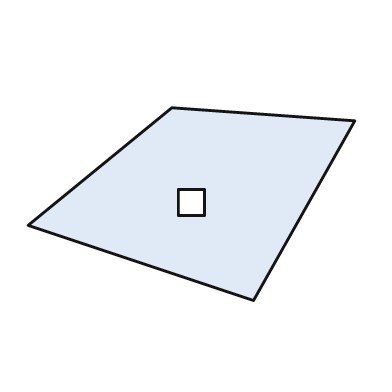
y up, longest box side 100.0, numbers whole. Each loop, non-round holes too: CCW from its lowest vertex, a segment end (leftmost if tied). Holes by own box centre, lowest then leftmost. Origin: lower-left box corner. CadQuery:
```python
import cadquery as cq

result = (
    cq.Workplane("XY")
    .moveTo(69.0, 0.0)
    .lineTo(100.0, 55.0)
    .lineTo(44.0, 59.0)
    .lineTo(0.0, 23.0)
    .close()
    .moveTo(46.0, 26.0)
    .lineTo(54.0, 26.0)
    .lineTo(54.0, 34.0)
    .lineTo(46.0, 34.0)
    .close()
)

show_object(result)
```